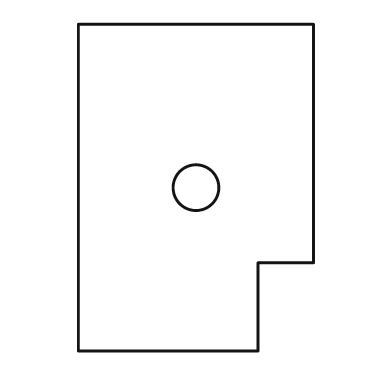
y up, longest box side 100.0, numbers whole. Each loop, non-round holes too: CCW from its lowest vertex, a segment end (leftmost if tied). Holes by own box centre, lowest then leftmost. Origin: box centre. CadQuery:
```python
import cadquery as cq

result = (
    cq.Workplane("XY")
    .moveTo(-36.0, -50.0)
    .lineTo(19.0, -50.0)
    .lineTo(19.0, -23.0)
    .lineTo(36.0, -23.0)
    .lineTo(36.0, 50.0)
    .lineTo(-36.0, 50.0)
    .close()
    .moveTo(0.0, 0.0)
    .circle(7.0)
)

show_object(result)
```